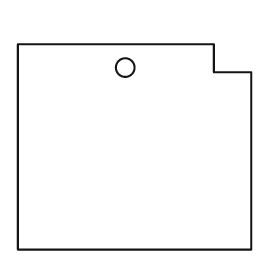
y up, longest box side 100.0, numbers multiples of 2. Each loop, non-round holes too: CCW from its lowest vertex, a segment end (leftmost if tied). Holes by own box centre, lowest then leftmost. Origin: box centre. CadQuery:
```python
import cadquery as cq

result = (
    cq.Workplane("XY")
    .moveTo(-50.0, -44.0)
    .lineTo(50.0, -44.0)
    .lineTo(50.0, 32.0)
    .lineTo(34.0, 32.0)
    .lineTo(34.0, 44.0)
    .lineTo(-50.0, 44.0)
    .close()
    .moveTo(-4.0, 34.0)
    .circle(4.0)
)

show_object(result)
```